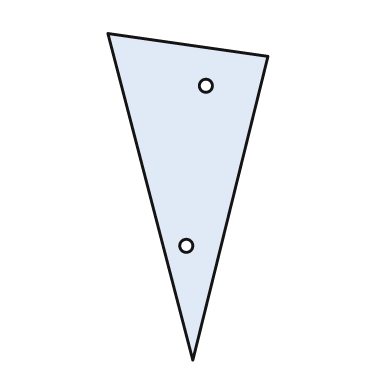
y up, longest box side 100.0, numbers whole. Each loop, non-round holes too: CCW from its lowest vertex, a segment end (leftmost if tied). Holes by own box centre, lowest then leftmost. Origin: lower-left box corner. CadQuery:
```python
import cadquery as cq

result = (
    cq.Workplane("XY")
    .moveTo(26.0, 0.0)
    .lineTo(49.0, 93.0)
    .lineTo(0.0, 100.0)
    .close()
    .moveTo(24.0, 35.0)
    .circle(2.0)
    .moveTo(30.0, 84.0)
    .circle(2.0)
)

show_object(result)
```